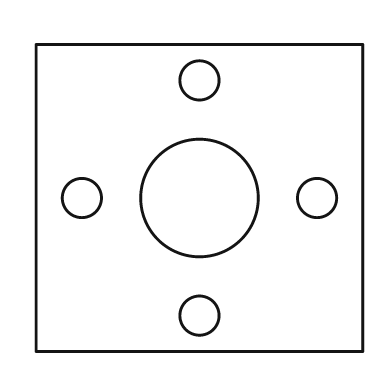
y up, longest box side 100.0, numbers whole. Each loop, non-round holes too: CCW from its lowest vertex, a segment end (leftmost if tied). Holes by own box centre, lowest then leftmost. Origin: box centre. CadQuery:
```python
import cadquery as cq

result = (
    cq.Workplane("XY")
    .moveTo(-50.0, -47.0)
    .lineTo(50.0, -47.0)
    .lineTo(50.0, 47.0)
    .lineTo(-50.0, 47.0)
    .close()
    .moveTo(0.0, -36.0)
    .circle(6.0)
    .moveTo(-36.0, 0.0)
    .circle(6.0)
    .moveTo(0.0, 0.0)
    .circle(18.0)
    .moveTo(36.0, 0.0)
    .circle(6.0)
    .moveTo(0.0, 36.0)
    .circle(6.0)
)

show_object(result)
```